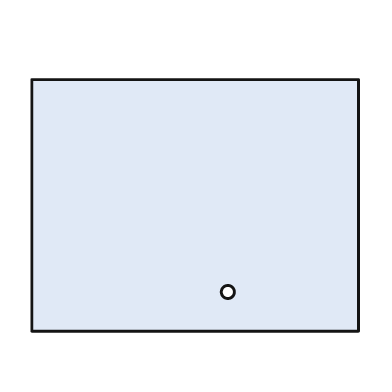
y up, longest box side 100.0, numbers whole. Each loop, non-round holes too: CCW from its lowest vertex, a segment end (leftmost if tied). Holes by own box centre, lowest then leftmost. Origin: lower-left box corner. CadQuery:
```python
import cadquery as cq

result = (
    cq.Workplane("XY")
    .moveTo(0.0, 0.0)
    .lineTo(100.0, 0.0)
    .lineTo(100.0, 77.0)
    .lineTo(0.0, 77.0)
    .close()
    .moveTo(60.0, 12.0)
    .circle(2.0)
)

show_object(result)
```